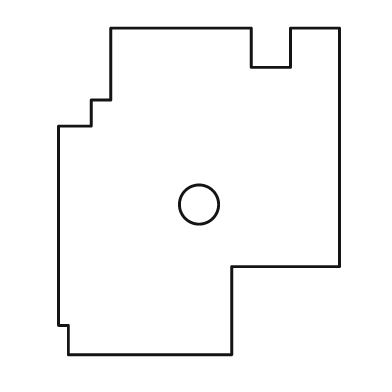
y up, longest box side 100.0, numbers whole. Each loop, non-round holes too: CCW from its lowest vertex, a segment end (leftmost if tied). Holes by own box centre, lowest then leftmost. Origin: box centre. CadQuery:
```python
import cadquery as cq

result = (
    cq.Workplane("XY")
    .moveTo(-40.0, -50.0)
    .lineTo(10.0, -50.0)
    .lineTo(10.0, -23.0)
    .lineTo(43.0, -23.0)
    .lineTo(43.0, 50.0)
    .lineTo(28.0, 50.0)
    .lineTo(28.0, 38.0)
    .lineTo(16.0, 38.0)
    .lineTo(16.0, 50.0)
    .lineTo(-27.0, 50.0)
    .lineTo(-27.0, 28.0)
    .lineTo(-33.0, 28.0)
    .lineTo(-33.0, 20.0)
    .lineTo(-43.0, 20.0)
    .lineTo(-43.0, -41.0)
    .lineTo(-40.0, -41.0)
    .close()
    .moveTo(0.0, -4.0)
    .circle(6.0)
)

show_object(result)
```